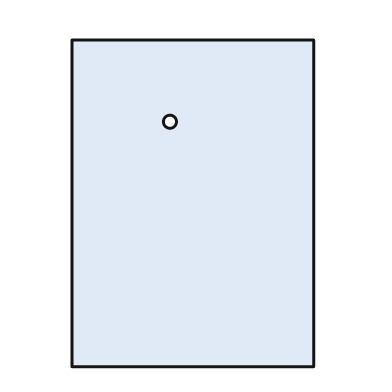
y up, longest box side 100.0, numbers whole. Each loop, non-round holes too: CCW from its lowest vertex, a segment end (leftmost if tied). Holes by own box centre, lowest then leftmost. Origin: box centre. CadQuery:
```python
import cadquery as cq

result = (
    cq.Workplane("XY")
    .moveTo(-37.0, -50.0)
    .lineTo(37.0, -50.0)
    .lineTo(37.0, 50.0)
    .lineTo(-37.0, 50.0)
    .close()
    .moveTo(-7.0, 25.0)
    .circle(2.0)
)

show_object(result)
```